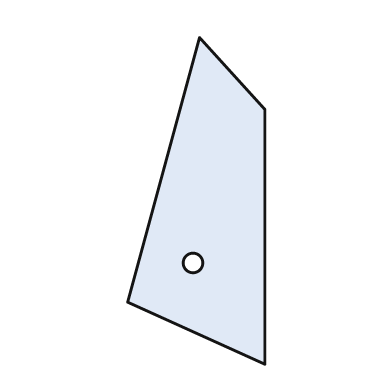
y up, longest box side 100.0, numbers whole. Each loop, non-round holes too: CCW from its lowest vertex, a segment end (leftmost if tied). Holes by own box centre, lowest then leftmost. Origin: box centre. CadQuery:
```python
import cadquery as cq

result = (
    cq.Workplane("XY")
    .moveTo(21.0, -50.0)
    .lineTo(21.0, 28.0)
    .lineTo(1.0, 50.0)
    .lineTo(-21.0, -31.0)
    .close()
    .moveTo(-1.0, -19.0)
    .circle(3.0)
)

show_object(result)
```